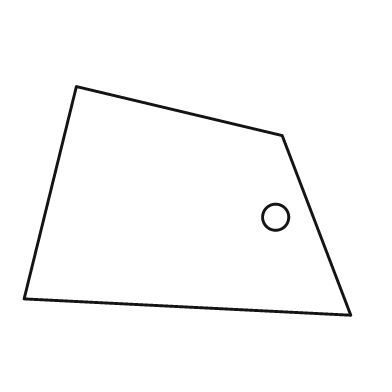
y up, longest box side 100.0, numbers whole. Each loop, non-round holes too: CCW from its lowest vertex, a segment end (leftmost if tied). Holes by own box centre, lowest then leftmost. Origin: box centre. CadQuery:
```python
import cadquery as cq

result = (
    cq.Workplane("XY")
    .moveTo(50.0, -35.0)
    .lineTo(29.0, 20.0)
    .lineTo(-34.0, 35.0)
    .lineTo(-50.0, -30.0)
    .close()
    .moveTo(27.0, -5.0)
    .circle(4.0)
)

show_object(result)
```